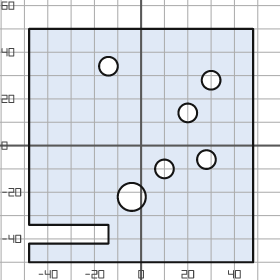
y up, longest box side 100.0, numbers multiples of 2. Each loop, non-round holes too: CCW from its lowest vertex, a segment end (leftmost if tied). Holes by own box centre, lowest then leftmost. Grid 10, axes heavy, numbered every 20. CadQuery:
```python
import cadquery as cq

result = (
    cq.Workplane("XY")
    .moveTo(-48.0, -50.0)
    .lineTo(48.0, -50.0)
    .lineTo(48.0, 50.0)
    .lineTo(-48.0, 50.0)
    .lineTo(-48.0, -34.0)
    .lineTo(-14.0, -34.0)
    .lineTo(-14.0, -42.0)
    .lineTo(-48.0, -42.0)
    .close()
    .moveTo(-4.0, -22.0)
    .circle(6.0)
    .moveTo(10.0, -10.0)
    .circle(4.0)
    .moveTo(28.0, -6.0)
    .circle(4.0)
    .moveTo(20.0, 14.0)
    .circle(4.0)
    .moveTo(30.0, 28.0)
    .circle(4.0)
    .moveTo(-14.0, 34.0)
    .circle(4.0)
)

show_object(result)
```